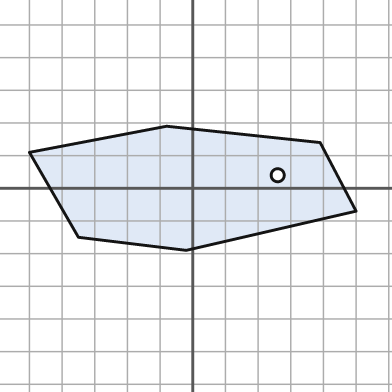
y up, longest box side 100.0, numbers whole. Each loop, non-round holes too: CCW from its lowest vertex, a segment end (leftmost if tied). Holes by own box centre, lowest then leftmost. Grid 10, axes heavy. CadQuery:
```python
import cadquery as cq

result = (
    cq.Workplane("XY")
    .moveTo(-2.0, -19.0)
    .lineTo(50.0, -7.0)
    .lineTo(39.0, 14.0)
    .lineTo(-8.0, 19.0)
    .lineTo(-50.0, 11.0)
    .lineTo(-35.0, -15.0)
    .close()
    .moveTo(26.0, 4.0)
    .circle(2.0)
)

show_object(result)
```